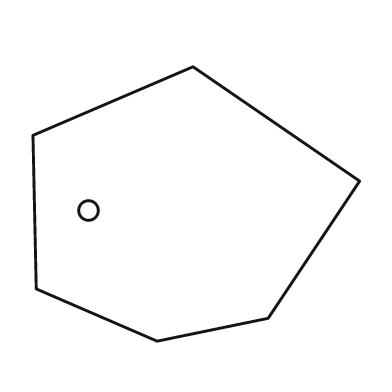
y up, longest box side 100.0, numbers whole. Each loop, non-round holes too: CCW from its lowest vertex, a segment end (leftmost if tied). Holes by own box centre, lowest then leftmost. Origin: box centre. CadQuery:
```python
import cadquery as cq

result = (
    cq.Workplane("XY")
    .moveTo(-12.0, -42.0)
    .lineTo(22.0, -35.0)
    .lineTo(50.0, 7.0)
    .lineTo(-1.0, 42.0)
    .lineTo(-50.0, 21.0)
    .lineTo(-49.0, -26.0)
    .close()
    .moveTo(-33.0, -2.0)
    .circle(3.0)
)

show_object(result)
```